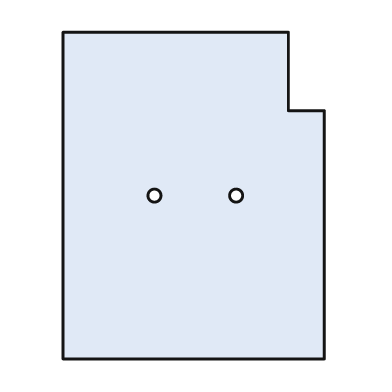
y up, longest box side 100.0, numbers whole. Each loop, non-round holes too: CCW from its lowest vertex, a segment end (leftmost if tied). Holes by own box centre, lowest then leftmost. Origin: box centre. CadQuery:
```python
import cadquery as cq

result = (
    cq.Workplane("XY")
    .moveTo(-40.0, -50.0)
    .lineTo(40.0, -50.0)
    .lineTo(40.0, 26.0)
    .lineTo(29.0, 26.0)
    .lineTo(29.0, 50.0)
    .lineTo(-40.0, 50.0)
    .close()
    .moveTo(-12.0, 0.0)
    .circle(2.0)
    .moveTo(13.0, 0.0)
    .circle(2.0)
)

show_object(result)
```